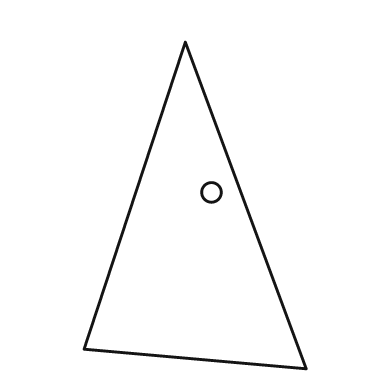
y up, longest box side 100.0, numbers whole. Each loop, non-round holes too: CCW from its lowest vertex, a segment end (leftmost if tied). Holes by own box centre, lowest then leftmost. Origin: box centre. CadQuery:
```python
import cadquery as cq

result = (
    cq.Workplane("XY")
    .moveTo(34.0, -50.0)
    .lineTo(-3.0, 50.0)
    .lineTo(-34.0, -44.0)
    .close()
    .moveTo(5.0, 4.0)
    .circle(3.0)
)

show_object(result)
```